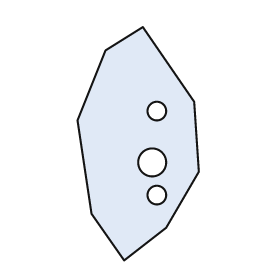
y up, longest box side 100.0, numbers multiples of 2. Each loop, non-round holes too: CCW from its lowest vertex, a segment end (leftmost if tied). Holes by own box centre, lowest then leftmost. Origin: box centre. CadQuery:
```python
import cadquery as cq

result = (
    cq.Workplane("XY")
    .moveTo(-6.0, -50.0)
    .lineTo(12.0, -36.0)
    .lineTo(26.0, -12.0)
    .lineTo(24.0, 18.0)
    .lineTo(2.0, 50.0)
    .lineTo(-14.0, 40.0)
    .lineTo(-26.0, 10.0)
    .lineTo(-20.0, -30.0)
    .close()
    .moveTo(8.0, -22.0)
    .circle(4.0)
    .moveTo(6.0, -8.0)
    .circle(6.0)
    .moveTo(8.0, 14.0)
    .circle(4.0)
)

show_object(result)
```